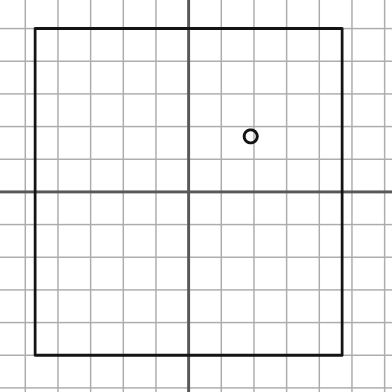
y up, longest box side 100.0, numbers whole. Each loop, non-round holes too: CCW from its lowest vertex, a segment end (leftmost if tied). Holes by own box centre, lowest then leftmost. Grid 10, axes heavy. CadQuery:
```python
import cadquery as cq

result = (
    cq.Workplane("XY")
    .moveTo(-47.0, -50.0)
    .lineTo(47.0, -50.0)
    .lineTo(47.0, 50.0)
    .lineTo(-47.0, 50.0)
    .close()
    .moveTo(19.0, 17.0)
    .circle(2.0)
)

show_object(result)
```